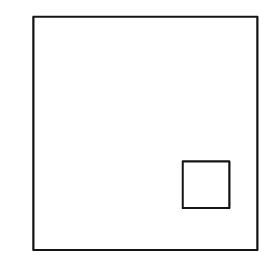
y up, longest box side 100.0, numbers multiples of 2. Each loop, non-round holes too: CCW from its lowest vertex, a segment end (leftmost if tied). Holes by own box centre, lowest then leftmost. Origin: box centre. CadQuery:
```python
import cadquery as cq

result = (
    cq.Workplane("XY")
    .moveTo(-48.0, -50.0)
    .lineTo(48.0, -50.0)
    .lineTo(48.0, 50.0)
    .lineTo(-48.0, 50.0)
    .close()
    .moveTo(16.0, -32.0)
    .lineTo(36.0, -32.0)
    .lineTo(36.0, -12.0)
    .lineTo(16.0, -12.0)
    .close()
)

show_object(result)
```